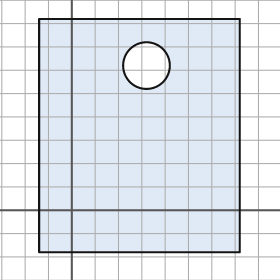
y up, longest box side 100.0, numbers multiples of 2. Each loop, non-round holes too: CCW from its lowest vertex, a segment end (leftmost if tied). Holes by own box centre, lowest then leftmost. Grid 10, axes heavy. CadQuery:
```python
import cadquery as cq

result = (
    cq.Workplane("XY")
    .moveTo(-14.0, -18.0)
    .lineTo(72.0, -18.0)
    .lineTo(72.0, 82.0)
    .lineTo(-14.0, 82.0)
    .close()
    .moveTo(32.0, 62.0)
    .circle(10.0)
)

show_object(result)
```